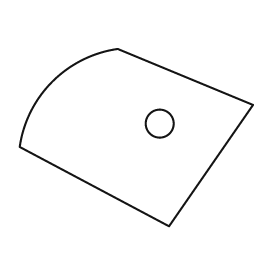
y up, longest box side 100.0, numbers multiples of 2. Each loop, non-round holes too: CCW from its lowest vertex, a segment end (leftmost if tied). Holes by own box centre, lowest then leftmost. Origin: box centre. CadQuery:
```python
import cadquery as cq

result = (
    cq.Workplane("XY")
    .moveTo(14.0, -38.0)
    .lineTo(50.0, 14.0)
    .lineTo(-8.0, 38.0)
    .threePointArc((-36.0, 24.0), (-50.0, -4.0))
    .close()
    .moveTo(10.0, 6.0)
    .circle(6.0)
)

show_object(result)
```